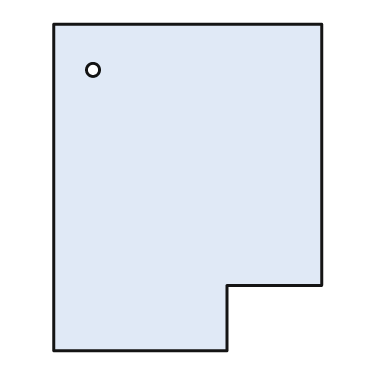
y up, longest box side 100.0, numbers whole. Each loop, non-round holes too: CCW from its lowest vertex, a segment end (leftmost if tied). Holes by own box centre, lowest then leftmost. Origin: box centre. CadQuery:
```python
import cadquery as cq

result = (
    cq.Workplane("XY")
    .moveTo(-41.0, -50.0)
    .lineTo(12.0, -50.0)
    .lineTo(12.0, -30.0)
    .lineTo(41.0, -30.0)
    .lineTo(41.0, 50.0)
    .lineTo(-41.0, 50.0)
    .close()
    .moveTo(-29.0, 36.0)
    .circle(2.0)
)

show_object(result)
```